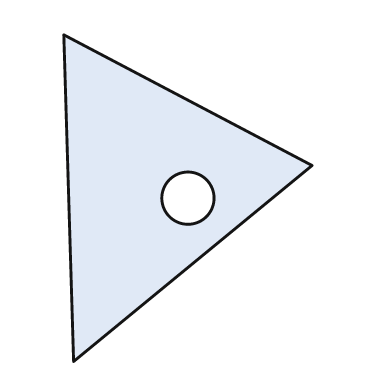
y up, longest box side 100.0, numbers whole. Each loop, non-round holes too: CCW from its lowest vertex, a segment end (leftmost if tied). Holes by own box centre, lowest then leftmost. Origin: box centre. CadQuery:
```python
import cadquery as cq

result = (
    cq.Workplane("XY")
    .moveTo(-35.0, -50.0)
    .lineTo(38.0, 10.0)
    .lineTo(-38.0, 50.0)
    .close()
    .moveTo(0.0, 0.0)
    .circle(8.0)
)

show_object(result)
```